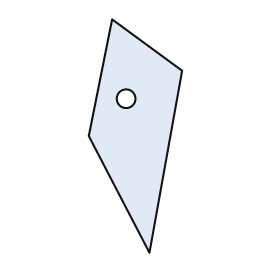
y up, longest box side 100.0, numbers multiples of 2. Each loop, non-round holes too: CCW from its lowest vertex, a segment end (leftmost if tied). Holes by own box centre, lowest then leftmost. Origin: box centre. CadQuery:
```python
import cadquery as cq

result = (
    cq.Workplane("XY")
    .moveTo(6.0, -50.0)
    .lineTo(20.0, 28.0)
    .lineTo(-10.0, 50.0)
    .lineTo(-20.0, 0.0)
    .close()
    .moveTo(-4.0, 16.0)
    .circle(4.0)
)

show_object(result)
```